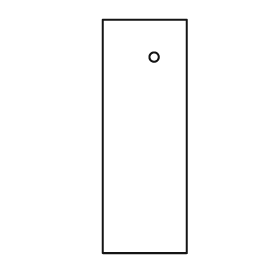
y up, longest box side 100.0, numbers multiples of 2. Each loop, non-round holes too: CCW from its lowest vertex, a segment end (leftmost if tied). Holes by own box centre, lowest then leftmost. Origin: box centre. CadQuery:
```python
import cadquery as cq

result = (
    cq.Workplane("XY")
    .moveTo(-18.0, -50.0)
    .lineTo(18.0, -50.0)
    .lineTo(18.0, 50.0)
    .lineTo(-18.0, 50.0)
    .close()
    .moveTo(4.0, 34.0)
    .circle(2.0)
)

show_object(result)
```